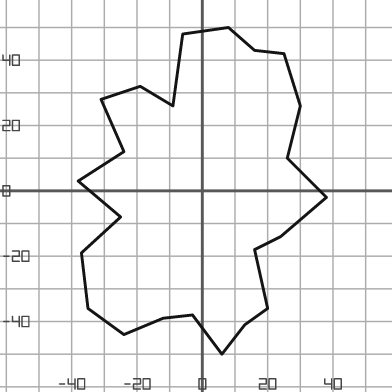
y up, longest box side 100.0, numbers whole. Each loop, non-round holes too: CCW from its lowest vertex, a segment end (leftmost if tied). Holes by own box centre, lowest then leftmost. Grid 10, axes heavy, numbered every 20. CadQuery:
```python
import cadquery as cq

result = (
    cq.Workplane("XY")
    .moveTo(6.0, -50.0)
    .lineTo(13.0, -41.0)
    .lineTo(20.0, -36.0)
    .lineTo(16.0, -18.0)
    .lineTo(24.0, -14.0)
    .lineTo(38.0, -2.0)
    .lineTo(26.0, 10.0)
    .lineTo(30.0, 26.0)
    .lineTo(25.0, 42.0)
    .lineTo(16.0, 43.0)
    .lineTo(8.0, 50.0)
    .lineTo(-6.0, 48.0)
    .lineTo(-9.0, 26.0)
    .lineTo(-19.0, 32.0)
    .lineTo(-31.0, 28.0)
    .lineTo(-24.0, 12.0)
    .lineTo(-38.0, 3.0)
    .lineTo(-25.0, -8.0)
    .lineTo(-37.0, -19.0)
    .lineTo(-35.0, -36.0)
    .lineTo(-24.0, -44.0)
    .lineTo(-12.0, -39.0)
    .lineTo(-3.0, -38.0)
    .close()
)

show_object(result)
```